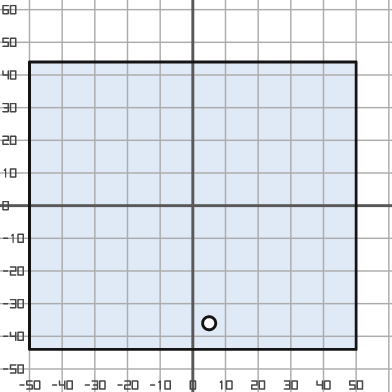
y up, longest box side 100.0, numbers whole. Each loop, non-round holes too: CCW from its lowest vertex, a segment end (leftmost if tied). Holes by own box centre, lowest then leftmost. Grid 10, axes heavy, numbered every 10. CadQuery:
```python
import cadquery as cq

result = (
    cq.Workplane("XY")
    .moveTo(-50.0, -44.0)
    .lineTo(50.0, -44.0)
    .lineTo(50.0, 44.0)
    .lineTo(-50.0, 44.0)
    .close()
    .moveTo(5.0, -36.0)
    .circle(2.0)
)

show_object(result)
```